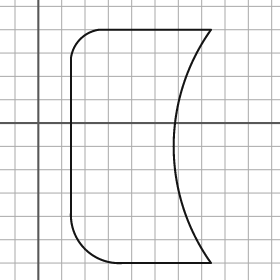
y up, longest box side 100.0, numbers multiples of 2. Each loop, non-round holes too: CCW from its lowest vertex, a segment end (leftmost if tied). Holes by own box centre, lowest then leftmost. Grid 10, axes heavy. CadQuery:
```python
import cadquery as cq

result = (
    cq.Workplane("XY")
    .moveTo(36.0, -60.0)
    .lineTo(74.0, -60.0)
    .threePointArc((58.0, -10.0), (74.0, 40.0))
    .lineTo(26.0, 40.0)
    .threePointArc((18.0, 36.0), (14.0, 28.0))
    .lineTo(14.0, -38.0)
    .threePointArc((20.0, -54.0), (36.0, -60.0))
    .close()
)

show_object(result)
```